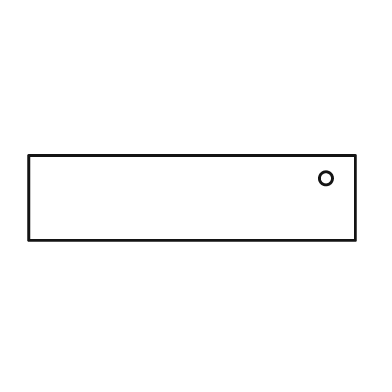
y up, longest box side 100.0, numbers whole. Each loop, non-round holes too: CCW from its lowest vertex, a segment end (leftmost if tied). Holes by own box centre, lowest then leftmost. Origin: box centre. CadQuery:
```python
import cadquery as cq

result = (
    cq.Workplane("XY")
    .moveTo(-50.0, -13.0)
    .lineTo(50.0, -13.0)
    .lineTo(50.0, 13.0)
    .lineTo(-50.0, 13.0)
    .close()
    .moveTo(41.0, 6.0)
    .circle(2.0)
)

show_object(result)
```